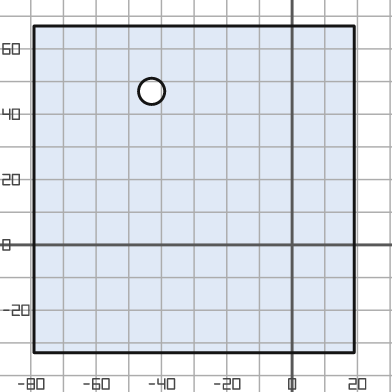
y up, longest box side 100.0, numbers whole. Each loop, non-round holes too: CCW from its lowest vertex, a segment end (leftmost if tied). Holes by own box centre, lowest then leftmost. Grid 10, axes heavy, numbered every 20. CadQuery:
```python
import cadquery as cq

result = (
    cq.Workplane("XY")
    .moveTo(-79.0, -33.0)
    .lineTo(19.0, -33.0)
    .lineTo(19.0, 67.0)
    .lineTo(-79.0, 67.0)
    .close()
    .moveTo(-43.0, 47.0)
    .circle(4.0)
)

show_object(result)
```